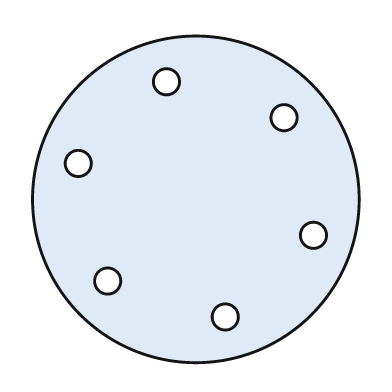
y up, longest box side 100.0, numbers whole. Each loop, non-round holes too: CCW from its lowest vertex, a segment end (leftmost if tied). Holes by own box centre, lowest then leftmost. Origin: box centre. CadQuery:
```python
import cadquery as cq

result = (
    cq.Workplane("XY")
    .moveTo(0.0, 0.0)
    .circle(50.0)
    .moveTo(9.0, -36.0)
    .circle(4.0)
    .moveTo(-27.0, -25.0)
    .circle(4.0)
    .moveTo(36.0, -11.0)
    .circle(4.0)
    .moveTo(-36.0, 11.0)
    .circle(4.0)
    .moveTo(27.0, 25.0)
    .circle(4.0)
    .moveTo(-9.0, 36.0)
    .circle(4.0)
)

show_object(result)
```